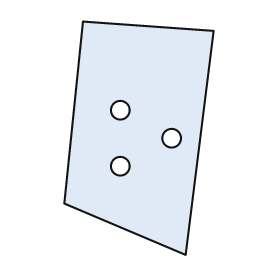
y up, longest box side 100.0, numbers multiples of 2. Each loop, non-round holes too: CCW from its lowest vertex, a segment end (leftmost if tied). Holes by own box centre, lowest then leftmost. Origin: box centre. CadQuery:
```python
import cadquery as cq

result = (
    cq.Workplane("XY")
    .moveTo(20.0, -50.0)
    .lineTo(32.0, 46.0)
    .lineTo(-24.0, 50.0)
    .lineTo(-32.0, -28.0)
    .close()
    .moveTo(-8.0, -12.0)
    .circle(4.0)
    .moveTo(14.0, 0.0)
    .circle(4.0)
    .moveTo(-8.0, 12.0)
    .circle(4.0)
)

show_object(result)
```